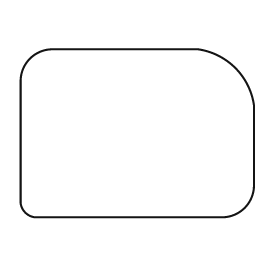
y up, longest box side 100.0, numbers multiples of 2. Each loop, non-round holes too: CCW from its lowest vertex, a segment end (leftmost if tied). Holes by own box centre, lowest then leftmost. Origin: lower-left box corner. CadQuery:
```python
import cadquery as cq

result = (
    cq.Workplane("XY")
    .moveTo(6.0, 0.0)
    .lineTo(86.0, 0.0)
    .threePointArc((96.0, 4.0), (100.0, 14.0))
    .lineTo(100.0, 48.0)
    .threePointArc((92.0, 64.0), (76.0, 72.0))
    .lineTo(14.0, 72.0)
    .threePointArc((4.0, 68.0), (0.0, 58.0))
    .lineTo(0.0, 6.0)
    .threePointArc((2.0, 2.0), (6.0, 0.0))
    .close()
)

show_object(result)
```